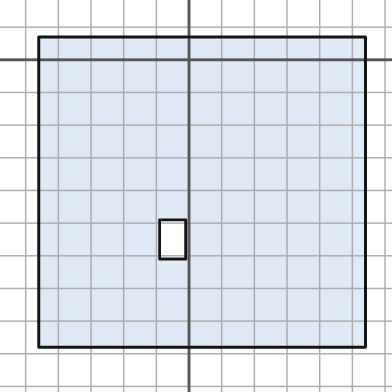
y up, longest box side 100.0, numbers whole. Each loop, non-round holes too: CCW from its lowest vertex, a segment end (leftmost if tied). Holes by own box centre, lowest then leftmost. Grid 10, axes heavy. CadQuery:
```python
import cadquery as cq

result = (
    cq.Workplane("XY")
    .moveTo(-46.0, -88.0)
    .lineTo(54.0, -88.0)
    .lineTo(54.0, 7.0)
    .lineTo(-46.0, 7.0)
    .close()
    .moveTo(-9.0, -61.0)
    .lineTo(-1.0, -61.0)
    .lineTo(-1.0, -49.0)
    .lineTo(-9.0, -49.0)
    .close()
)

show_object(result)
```